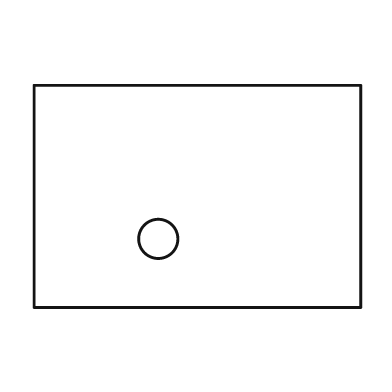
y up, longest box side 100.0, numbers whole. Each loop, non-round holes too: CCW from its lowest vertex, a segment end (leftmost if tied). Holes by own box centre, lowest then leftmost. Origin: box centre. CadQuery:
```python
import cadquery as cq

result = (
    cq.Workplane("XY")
    .moveTo(-50.0, -34.0)
    .lineTo(50.0, -34.0)
    .lineTo(50.0, 34.0)
    .lineTo(-50.0, 34.0)
    .close()
    .moveTo(-12.0, -13.0)
    .circle(6.0)
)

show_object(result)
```